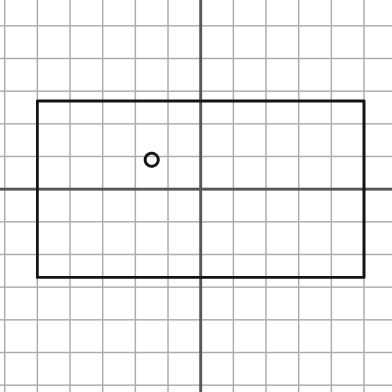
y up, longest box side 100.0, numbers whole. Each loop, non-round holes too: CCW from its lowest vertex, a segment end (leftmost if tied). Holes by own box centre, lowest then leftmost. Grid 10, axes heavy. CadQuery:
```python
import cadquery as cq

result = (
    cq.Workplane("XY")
    .moveTo(-50.0, -27.0)
    .lineTo(50.0, -27.0)
    .lineTo(50.0, 27.0)
    .lineTo(-50.0, 27.0)
    .close()
    .moveTo(-15.0, 9.0)
    .circle(2.0)
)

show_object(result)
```